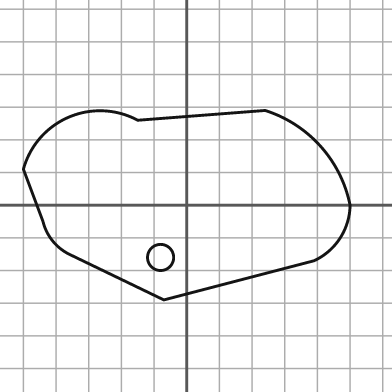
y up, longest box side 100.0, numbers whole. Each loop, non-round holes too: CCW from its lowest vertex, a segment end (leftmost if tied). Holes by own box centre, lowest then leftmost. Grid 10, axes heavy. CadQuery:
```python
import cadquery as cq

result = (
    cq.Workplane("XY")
    .moveTo(-7.0, -29.0)
    .lineTo(39.0, -17.0)
    .threePointArc((47.0, -10.0), (50.0, 0.0))
    .threePointArc((41.0, 18.0), (24.0, 29.0))
    .lineTo(-15.0, 26.0)
    .threePointArc((-36.0, 27.0), (-50.0, 11.0))
    .lineTo(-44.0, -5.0)
    .threePointArc((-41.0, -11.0), (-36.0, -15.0))
    .close()
    .moveTo(-8.0, -16.0)
    .circle(4.0)
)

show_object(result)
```